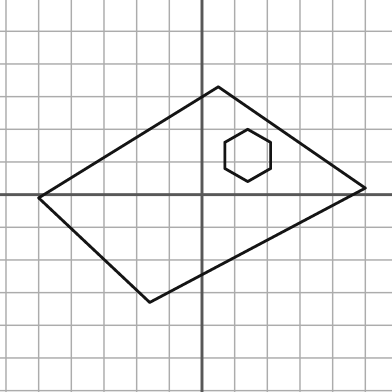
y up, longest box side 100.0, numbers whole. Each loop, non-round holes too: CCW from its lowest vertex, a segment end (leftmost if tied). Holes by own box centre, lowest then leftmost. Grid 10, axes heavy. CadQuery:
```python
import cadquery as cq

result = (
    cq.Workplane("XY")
    .moveTo(-16.0, -33.0)
    .lineTo(50.0, 2.0)
    .lineTo(5.0, 33.0)
    .lineTo(-50.0, -1.0)
    .close()
    .moveTo(14.0, 4.0)
    .lineTo(21.0, 8.0)
    .lineTo(21.0, 16.0)
    .lineTo(14.0, 20.0)
    .lineTo(7.0, 16.0)
    .lineTo(7.0, 8.0)
    .close()
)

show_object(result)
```